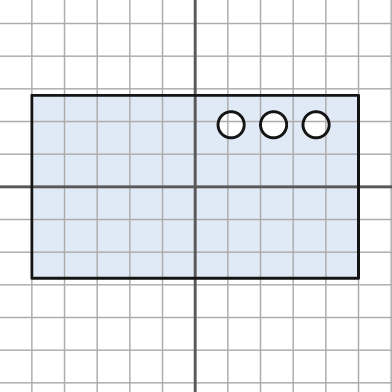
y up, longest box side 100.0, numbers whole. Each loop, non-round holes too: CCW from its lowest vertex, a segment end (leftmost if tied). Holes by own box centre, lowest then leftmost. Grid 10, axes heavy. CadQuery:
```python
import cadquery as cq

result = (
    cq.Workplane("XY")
    .moveTo(-50.0, -28.0)
    .lineTo(50.0, -28.0)
    .lineTo(50.0, 28.0)
    .lineTo(-50.0, 28.0)
    .close()
    .moveTo(11.0, 19.0)
    .circle(4.0)
    .moveTo(24.0, 19.0)
    .circle(4.0)
    .moveTo(37.0, 19.0)
    .circle(4.0)
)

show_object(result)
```